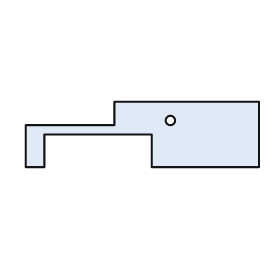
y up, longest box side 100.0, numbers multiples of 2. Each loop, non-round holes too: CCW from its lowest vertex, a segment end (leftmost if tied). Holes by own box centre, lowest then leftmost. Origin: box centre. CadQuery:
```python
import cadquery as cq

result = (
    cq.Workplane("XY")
    .moveTo(-50.0, -14.0)
    .lineTo(-42.0, -14.0)
    .lineTo(-42.0, 0.0)
    .lineTo(4.0, 0.0)
    .lineTo(4.0, -14.0)
    .lineTo(50.0, -14.0)
    .lineTo(50.0, 14.0)
    .lineTo(-12.0, 14.0)
    .lineTo(-12.0, 4.0)
    .lineTo(-50.0, 4.0)
    .close()
    .moveTo(12.0, 6.0)
    .circle(2.0)
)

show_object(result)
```